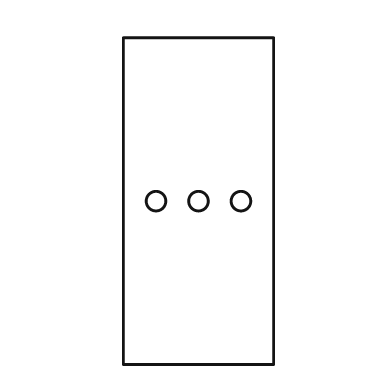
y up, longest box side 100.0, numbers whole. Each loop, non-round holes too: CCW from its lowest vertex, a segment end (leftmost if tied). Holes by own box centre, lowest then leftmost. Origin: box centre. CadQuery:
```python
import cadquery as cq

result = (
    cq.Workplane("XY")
    .moveTo(-23.0, -50.0)
    .lineTo(23.0, -50.0)
    .lineTo(23.0, 50.0)
    .lineTo(-23.0, 50.0)
    .close()
    .moveTo(-13.0, 0.0)
    .circle(3.0)
    .moveTo(0.0, 0.0)
    .circle(3.0)
    .moveTo(13.0, 0.0)
    .circle(3.0)
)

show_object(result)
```